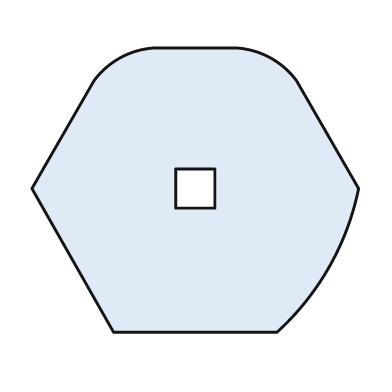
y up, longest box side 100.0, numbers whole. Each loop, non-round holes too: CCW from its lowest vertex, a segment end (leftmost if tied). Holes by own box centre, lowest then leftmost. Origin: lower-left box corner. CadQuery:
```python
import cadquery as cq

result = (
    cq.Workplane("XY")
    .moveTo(25.0, 0.0)
    .lineTo(75.0, 0.0)
    .threePointArc((91.0, 20.0), (100.0, 44.0))
    .lineTo(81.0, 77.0)
    .threePointArc((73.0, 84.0), (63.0, 87.0))
    .lineTo(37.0, 87.0)
    .threePointArc((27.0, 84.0), (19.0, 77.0))
    .lineTo(0.0, 44.0)
    .close()
    .moveTo(44.0, 38.0)
    .lineTo(56.0, 38.0)
    .lineTo(56.0, 50.0)
    .lineTo(44.0, 50.0)
    .close()
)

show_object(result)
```